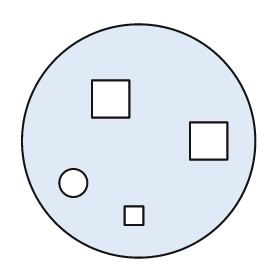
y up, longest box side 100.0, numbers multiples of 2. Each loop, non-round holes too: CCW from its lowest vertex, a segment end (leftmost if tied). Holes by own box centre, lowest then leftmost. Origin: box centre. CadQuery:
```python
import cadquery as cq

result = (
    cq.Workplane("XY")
    .moveTo(0.0, 0.0)
    .circle(50.0)
    .moveTo(-6.0, -36.0)
    .lineTo(2.0, -36.0)
    .lineTo(2.0, -28.0)
    .lineTo(-6.0, -28.0)
    .close()
    .moveTo(-28.0, -18.0)
    .circle(6.0)
    .moveTo(22.0, -8.0)
    .lineTo(38.0, -8.0)
    .lineTo(38.0, 8.0)
    .lineTo(22.0, 8.0)
    .close()
    .moveTo(-20.0, 10.0)
    .lineTo(-4.0, 10.0)
    .lineTo(-4.0, 26.0)
    .lineTo(-20.0, 26.0)
    .close()
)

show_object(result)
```